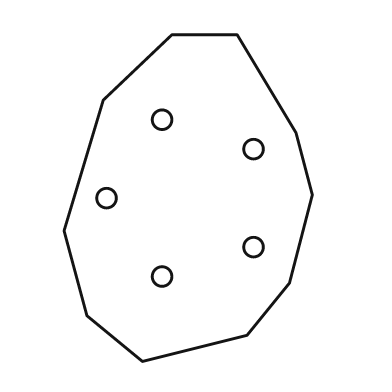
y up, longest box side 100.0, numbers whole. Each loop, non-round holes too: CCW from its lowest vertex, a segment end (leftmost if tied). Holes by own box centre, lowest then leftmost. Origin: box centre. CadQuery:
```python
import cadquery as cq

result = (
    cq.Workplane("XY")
    .moveTo(-14.0, -50.0)
    .lineTo(18.0, -42.0)
    .lineTo(31.0, -26.0)
    .lineTo(38.0, 1.0)
    .lineTo(33.0, 20.0)
    .lineTo(15.0, 50.0)
    .lineTo(-5.0, 50.0)
    .lineTo(-26.0, 30.0)
    .lineTo(-38.0, -10.0)
    .lineTo(-31.0, -36.0)
    .close()
    .moveTo(-8.0, -24.0)
    .circle(3.0)
    .moveTo(20.0, -15.0)
    .circle(3.0)
    .moveTo(-25.0, 0.0)
    .circle(3.0)
    .moveTo(20.0, 15.0)
    .circle(3.0)
    .moveTo(-8.0, 24.0)
    .circle(3.0)
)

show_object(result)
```